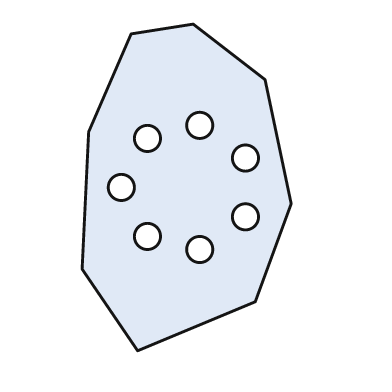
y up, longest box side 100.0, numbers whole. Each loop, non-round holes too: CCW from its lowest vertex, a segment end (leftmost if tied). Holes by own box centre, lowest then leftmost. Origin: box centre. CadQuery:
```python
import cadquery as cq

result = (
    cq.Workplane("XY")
    .moveTo(-15.0, -50.0)
    .lineTo(21.0, -35.0)
    .lineTo(32.0, -5.0)
    .lineTo(24.0, 33.0)
    .lineTo(2.0, 50.0)
    .lineTo(-17.0, 47.0)
    .lineTo(-30.0, 17.0)
    .lineTo(-32.0, -25.0)
    .close()
    .moveTo(4.0, -19.0)
    .circle(4.0)
    .moveTo(-12.0, -15.0)
    .circle(4.0)
    .moveTo(18.0, -9.0)
    .circle(4.0)
    .moveTo(-20.0, 0.0)
    .circle(4.0)
    .moveTo(18.0, 9.0)
    .circle(4.0)
    .moveTo(-12.0, 15.0)
    .circle(4.0)
    .moveTo(4.0, 19.0)
    .circle(4.0)
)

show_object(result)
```